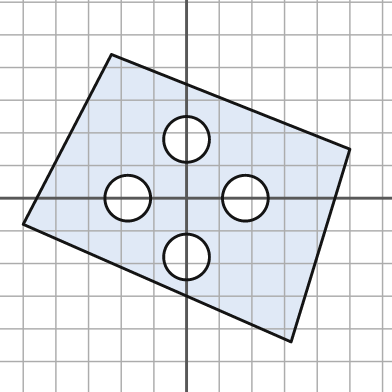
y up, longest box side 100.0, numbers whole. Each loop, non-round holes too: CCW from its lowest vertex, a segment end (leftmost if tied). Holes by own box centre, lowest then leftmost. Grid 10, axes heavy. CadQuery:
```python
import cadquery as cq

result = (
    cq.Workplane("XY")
    .moveTo(32.0, -44.0)
    .lineTo(50.0, 15.0)
    .lineTo(-23.0, 44.0)
    .lineTo(-50.0, -8.0)
    .close()
    .moveTo(0.0, -18.0)
    .circle(7.0)
    .moveTo(-18.0, 0.0)
    .circle(7.0)
    .moveTo(18.0, 0.0)
    .circle(7.0)
    .moveTo(0.0, 18.0)
    .circle(7.0)
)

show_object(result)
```